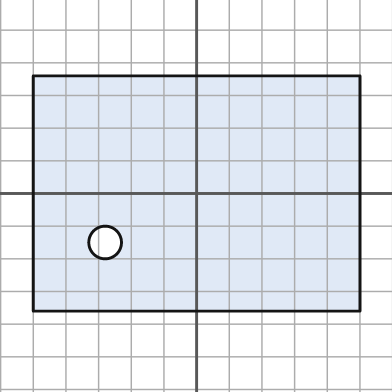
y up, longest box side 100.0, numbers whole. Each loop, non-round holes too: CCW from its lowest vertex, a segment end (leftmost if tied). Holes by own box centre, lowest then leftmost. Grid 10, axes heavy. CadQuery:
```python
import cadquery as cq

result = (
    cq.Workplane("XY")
    .moveTo(-50.0, -36.0)
    .lineTo(50.0, -36.0)
    .lineTo(50.0, 36.0)
    .lineTo(-50.0, 36.0)
    .close()
    .moveTo(-28.0, -15.0)
    .circle(5.0)
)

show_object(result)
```